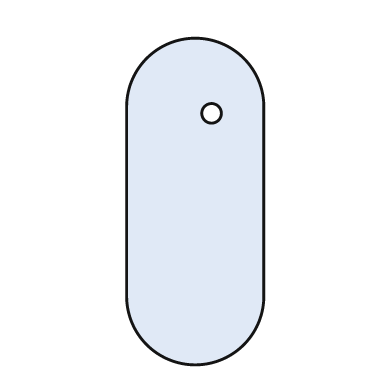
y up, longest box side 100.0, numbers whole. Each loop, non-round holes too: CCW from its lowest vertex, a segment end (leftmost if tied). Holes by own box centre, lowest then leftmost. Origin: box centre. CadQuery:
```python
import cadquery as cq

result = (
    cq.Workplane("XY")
    .moveTo(-21.0, -29.0)
    .threePointArc((0.0, -50.0), (21.0, -29.0))
    .lineTo(21.0, 29.0)
    .threePointArc((0.0, 50.0), (-21.0, 29.0))
    .close()
    .moveTo(5.0, 27.0)
    .circle(3.0)
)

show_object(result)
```